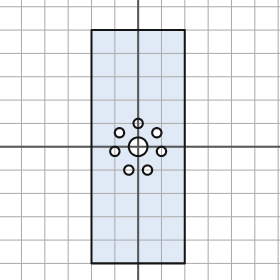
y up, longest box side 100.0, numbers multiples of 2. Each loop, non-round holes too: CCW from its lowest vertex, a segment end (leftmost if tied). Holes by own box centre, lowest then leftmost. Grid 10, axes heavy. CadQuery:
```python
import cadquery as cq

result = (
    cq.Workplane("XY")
    .moveTo(-20.0, -50.0)
    .lineTo(20.0, -50.0)
    .lineTo(20.0, 50.0)
    .lineTo(-20.0, 50.0)
    .close()
    .moveTo(-4.0, -10.0)
    .circle(2.0)
    .moveTo(4.0, -10.0)
    .circle(2.0)
    .moveTo(-10.0, -2.0)
    .circle(2.0)
    .moveTo(10.0, -2.0)
    .circle(2.0)
    .moveTo(0.0, 0.0)
    .circle(4.0)
    .moveTo(-8.0, 6.0)
    .circle(2.0)
    .moveTo(8.0, 6.0)
    .circle(2.0)
    .moveTo(0.0, 10.0)
    .circle(2.0)
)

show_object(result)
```